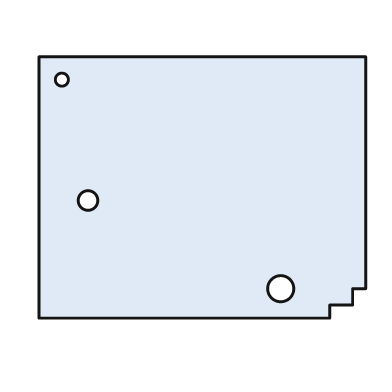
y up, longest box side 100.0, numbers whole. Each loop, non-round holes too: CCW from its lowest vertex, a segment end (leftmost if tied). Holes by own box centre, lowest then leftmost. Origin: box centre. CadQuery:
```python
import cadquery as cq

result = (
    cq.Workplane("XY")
    .moveTo(-50.0, -40.0)
    .lineTo(39.0, -40.0)
    .lineTo(39.0, -36.0)
    .lineTo(46.0, -36.0)
    .lineTo(46.0, -31.0)
    .lineTo(50.0, -31.0)
    .lineTo(50.0, 40.0)
    .lineTo(-50.0, 40.0)
    .close()
    .moveTo(24.0, -31.0)
    .circle(4.0)
    .moveTo(-35.0, -4.0)
    .circle(3.0)
    .moveTo(-43.0, 33.0)
    .circle(2.0)
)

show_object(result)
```